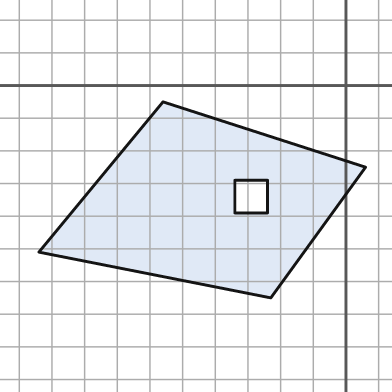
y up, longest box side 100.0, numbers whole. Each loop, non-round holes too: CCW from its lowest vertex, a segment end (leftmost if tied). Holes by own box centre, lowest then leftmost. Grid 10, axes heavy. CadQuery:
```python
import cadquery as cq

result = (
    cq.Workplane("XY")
    .moveTo(-23.0, -65.0)
    .lineTo(6.0, -25.0)
    .lineTo(-56.0, -5.0)
    .lineTo(-94.0, -51.0)
    .close()
    .moveTo(-34.0, -39.0)
    .lineTo(-24.0, -39.0)
    .lineTo(-24.0, -29.0)
    .lineTo(-34.0, -29.0)
    .close()
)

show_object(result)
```